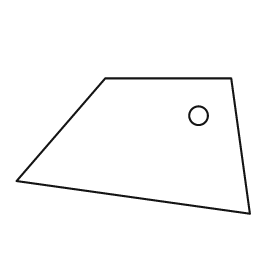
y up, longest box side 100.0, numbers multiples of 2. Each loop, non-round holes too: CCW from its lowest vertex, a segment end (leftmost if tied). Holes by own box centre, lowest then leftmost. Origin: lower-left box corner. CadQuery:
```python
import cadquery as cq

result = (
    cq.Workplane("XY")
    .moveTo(100.0, 0.0)
    .lineTo(92.0, 58.0)
    .lineTo(38.0, 58.0)
    .lineTo(0.0, 14.0)
    .close()
    .moveTo(78.0, 42.0)
    .circle(4.0)
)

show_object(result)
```